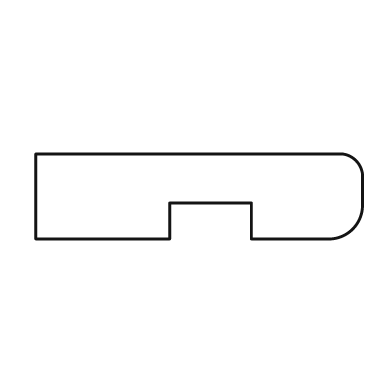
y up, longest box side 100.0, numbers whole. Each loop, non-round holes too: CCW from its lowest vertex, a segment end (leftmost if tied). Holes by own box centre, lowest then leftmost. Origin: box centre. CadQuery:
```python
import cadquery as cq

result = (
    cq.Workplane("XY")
    .moveTo(-50.0, -13.0)
    .lineTo(-9.0, -13.0)
    .lineTo(-9.0, -2.0)
    .lineTo(16.0, -2.0)
    .lineTo(16.0, -13.0)
    .lineTo(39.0, -13.0)
    .threePointArc((47.0, -10.0), (50.0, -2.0))
    .lineTo(50.0, 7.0)
    .threePointArc((48.0, 11.0), (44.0, 13.0))
    .lineTo(-50.0, 13.0)
    .close()
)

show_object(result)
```